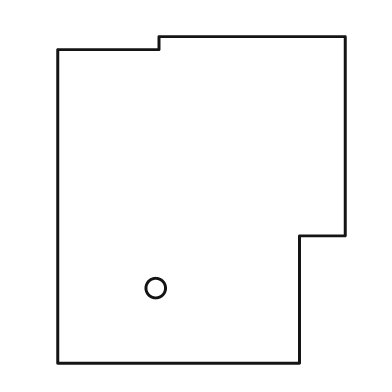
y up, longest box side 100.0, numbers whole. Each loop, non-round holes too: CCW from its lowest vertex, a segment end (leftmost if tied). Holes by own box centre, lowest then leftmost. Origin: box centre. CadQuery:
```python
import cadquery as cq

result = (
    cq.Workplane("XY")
    .moveTo(-44.0, -50.0)
    .lineTo(30.0, -50.0)
    .lineTo(30.0, -11.0)
    .lineTo(44.0, -11.0)
    .lineTo(44.0, 50.0)
    .lineTo(-13.0, 50.0)
    .lineTo(-13.0, 46.0)
    .lineTo(-44.0, 46.0)
    .close()
    .moveTo(-14.0, -27.0)
    .circle(3.0)
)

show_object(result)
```